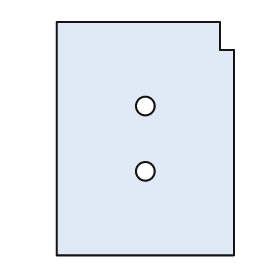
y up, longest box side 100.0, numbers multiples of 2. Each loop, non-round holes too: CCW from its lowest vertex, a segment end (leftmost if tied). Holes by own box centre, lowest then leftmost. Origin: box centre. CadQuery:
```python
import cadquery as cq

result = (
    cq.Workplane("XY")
    .moveTo(-38.0, -50.0)
    .lineTo(38.0, -50.0)
    .lineTo(38.0, 38.0)
    .lineTo(32.0, 38.0)
    .lineTo(32.0, 50.0)
    .lineTo(-38.0, 50.0)
    .close()
    .moveTo(0.0, -14.0)
    .circle(4.0)
    .moveTo(0.0, 14.0)
    .circle(4.0)
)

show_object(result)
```